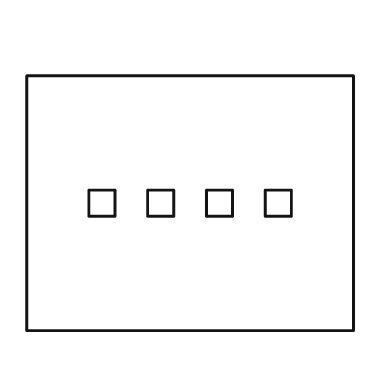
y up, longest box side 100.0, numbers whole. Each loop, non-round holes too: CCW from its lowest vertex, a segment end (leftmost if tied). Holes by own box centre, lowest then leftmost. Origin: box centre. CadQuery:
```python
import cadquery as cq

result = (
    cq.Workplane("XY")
    .moveTo(-50.0, -39.0)
    .lineTo(50.0, -39.0)
    .lineTo(50.0, 39.0)
    .lineTo(-50.0, 39.0)
    .close()
    .moveTo(-31.0, -4.0)
    .lineTo(-23.0, -4.0)
    .lineTo(-23.0, 4.0)
    .lineTo(-31.0, 4.0)
    .close()
    .moveTo(-13.0, -4.0)
    .lineTo(-5.0, -4.0)
    .lineTo(-5.0, 4.0)
    .lineTo(-13.0, 4.0)
    .close()
    .moveTo(5.0, -4.0)
    .lineTo(13.0, -4.0)
    .lineTo(13.0, 4.0)
    .lineTo(5.0, 4.0)
    .close()
    .moveTo(23.0, -4.0)
    .lineTo(31.0, -4.0)
    .lineTo(31.0, 4.0)
    .lineTo(23.0, 4.0)
    .close()
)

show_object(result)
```